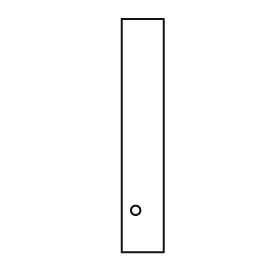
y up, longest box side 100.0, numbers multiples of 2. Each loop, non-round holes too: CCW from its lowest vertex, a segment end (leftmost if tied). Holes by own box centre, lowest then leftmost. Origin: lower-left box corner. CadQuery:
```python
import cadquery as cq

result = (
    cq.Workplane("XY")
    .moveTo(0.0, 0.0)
    .lineTo(18.0, 0.0)
    .lineTo(18.0, 100.0)
    .lineTo(0.0, 100.0)
    .close()
    .moveTo(6.0, 18.0)
    .circle(2.0)
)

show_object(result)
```